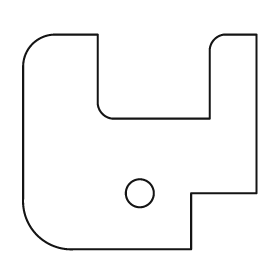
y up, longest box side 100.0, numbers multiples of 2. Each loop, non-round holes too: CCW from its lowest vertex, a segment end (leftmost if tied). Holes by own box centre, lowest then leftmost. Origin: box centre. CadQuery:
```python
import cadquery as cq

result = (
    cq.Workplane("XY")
    .moveTo(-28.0, -46.0)
    .lineTo(22.0, -46.0)
    .lineTo(22.0, -22.0)
    .lineTo(50.0, -22.0)
    .lineTo(50.0, 46.0)
    .lineTo(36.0, 46.0)
    .threePointArc((32.0, 44.0), (30.0, 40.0))
    .lineTo(30.0, 10.0)
    .lineTo(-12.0, 10.0)
    .threePointArc((-16.0, 12.0), (-18.0, 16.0))
    .lineTo(-18.0, 46.0)
    .lineTo(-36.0, 46.0)
    .threePointArc((-46.0, 42.0), (-50.0, 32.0))
    .lineTo(-50.0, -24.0)
    .threePointArc((-44.0, -40.0), (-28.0, -46.0))
    .close()
    .moveTo(0.0, -22.0)
    .circle(6.0)
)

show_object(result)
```